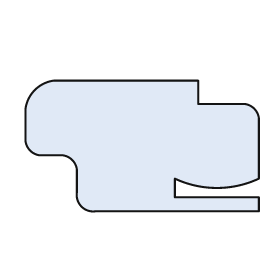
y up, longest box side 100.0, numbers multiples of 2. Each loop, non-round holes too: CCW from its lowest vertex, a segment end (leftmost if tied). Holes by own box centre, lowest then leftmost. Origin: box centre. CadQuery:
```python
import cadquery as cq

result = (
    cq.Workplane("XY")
    .moveTo(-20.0, -28.0)
    .lineTo(50.0, -28.0)
    .lineTo(50.0, -22.0)
    .lineTo(14.0, -22.0)
    .lineTo(14.0, -14.0)
    .threePointArc((32.0, -18.0), (50.0, -14.0))
    .lineTo(50.0, 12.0)
    .threePointArc((48.0, 16.0), (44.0, 18.0))
    .lineTo(24.0, 18.0)
    .lineTo(24.0, 28.0)
    .lineTo(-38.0, 28.0)
    .threePointArc((-46.0, 24.0), (-50.0, 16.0))
    .lineTo(-50.0, 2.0)
    .threePointArc((-48.0, -2.0), (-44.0, -4.0))
    .lineTo(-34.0, -4.0)
    .threePointArc((-30.0, -6.0), (-28.0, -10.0))
    .lineTo(-28.0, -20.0)
    .threePointArc((-26.0, -26.0), (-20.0, -28.0))
    .close()
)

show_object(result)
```